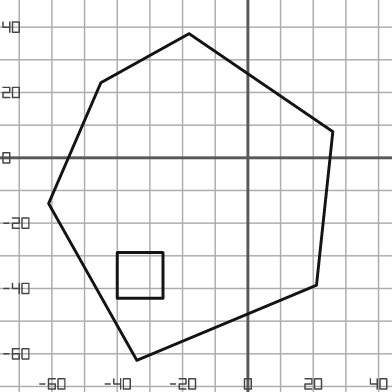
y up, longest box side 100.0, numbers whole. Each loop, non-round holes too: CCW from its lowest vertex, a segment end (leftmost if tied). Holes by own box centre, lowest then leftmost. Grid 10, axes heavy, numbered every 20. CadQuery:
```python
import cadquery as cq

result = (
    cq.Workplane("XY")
    .moveTo(-34.0, -62.0)
    .lineTo(21.0, -39.0)
    .lineTo(26.0, 8.0)
    .lineTo(-18.0, 38.0)
    .lineTo(-45.0, 23.0)
    .lineTo(-61.0, -14.0)
    .close()
    .moveTo(-40.0, -43.0)
    .lineTo(-26.0, -43.0)
    .lineTo(-26.0, -29.0)
    .lineTo(-40.0, -29.0)
    .close()
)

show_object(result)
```